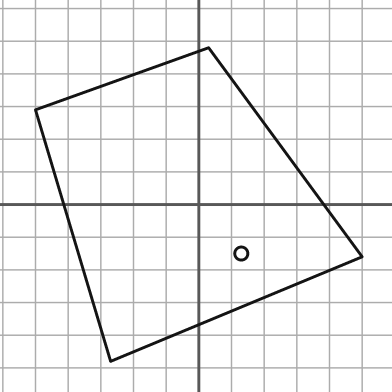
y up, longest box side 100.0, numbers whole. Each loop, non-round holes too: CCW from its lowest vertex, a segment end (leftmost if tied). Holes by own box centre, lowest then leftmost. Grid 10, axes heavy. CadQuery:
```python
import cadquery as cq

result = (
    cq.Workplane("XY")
    .moveTo(-27.0, -48.0)
    .lineTo(50.0, -16.0)
    .lineTo(3.0, 48.0)
    .lineTo(-50.0, 29.0)
    .close()
    .moveTo(13.0, -15.0)
    .circle(2.0)
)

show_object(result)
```